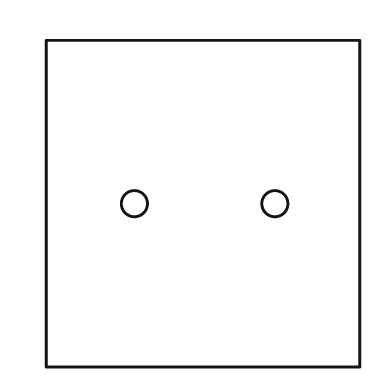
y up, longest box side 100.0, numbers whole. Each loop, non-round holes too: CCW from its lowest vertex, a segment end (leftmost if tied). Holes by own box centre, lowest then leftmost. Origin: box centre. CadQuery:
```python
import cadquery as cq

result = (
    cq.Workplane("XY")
    .moveTo(-48.0, -50.0)
    .lineTo(48.0, -50.0)
    .lineTo(48.0, 50.0)
    .lineTo(-48.0, 50.0)
    .close()
    .moveTo(-21.0, 0.0)
    .circle(4.0)
    .moveTo(22.0, 0.0)
    .circle(4.0)
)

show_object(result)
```